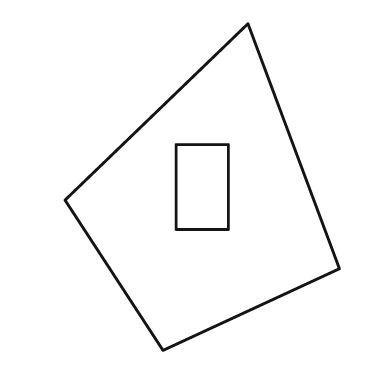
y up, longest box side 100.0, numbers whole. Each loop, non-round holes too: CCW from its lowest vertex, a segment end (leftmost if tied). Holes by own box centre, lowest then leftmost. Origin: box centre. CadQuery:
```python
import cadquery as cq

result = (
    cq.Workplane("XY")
    .moveTo(-12.0, -50.0)
    .lineTo(42.0, -25.0)
    .lineTo(14.0, 50.0)
    .lineTo(-42.0, -4.0)
    .close()
    .moveTo(-8.0, -13.0)
    .lineTo(8.0, -13.0)
    .lineTo(8.0, 13.0)
    .lineTo(-8.0, 13.0)
    .close()
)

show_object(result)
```